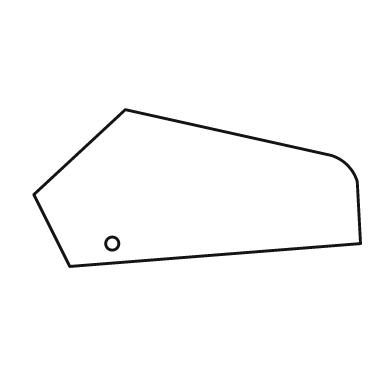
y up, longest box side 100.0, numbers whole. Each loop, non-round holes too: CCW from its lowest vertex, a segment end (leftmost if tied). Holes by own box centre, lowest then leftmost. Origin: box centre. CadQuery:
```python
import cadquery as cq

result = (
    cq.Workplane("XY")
    .moveTo(-39.0, -24.0)
    .lineTo(50.0, -17.0)
    .lineTo(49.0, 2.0)
    .threePointArc((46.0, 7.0), (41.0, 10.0))
    .lineTo(-22.0, 24.0)
    .lineTo(-50.0, -2.0)
    .close()
    .moveTo(-26.0, -17.0)
    .circle(2.0)
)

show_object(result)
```